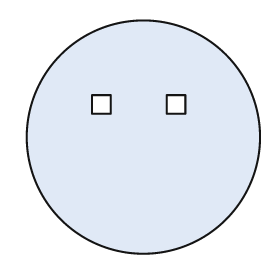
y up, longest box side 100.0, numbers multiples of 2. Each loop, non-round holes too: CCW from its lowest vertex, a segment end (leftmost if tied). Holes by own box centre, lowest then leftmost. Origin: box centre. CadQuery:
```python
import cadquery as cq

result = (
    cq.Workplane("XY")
    .moveTo(0.0, 0.0)
    .circle(50.0)
    .moveTo(-22.0, 10.0)
    .lineTo(-14.0, 10.0)
    .lineTo(-14.0, 18.0)
    .lineTo(-22.0, 18.0)
    .close()
    .moveTo(10.0, 10.0)
    .lineTo(18.0, 10.0)
    .lineTo(18.0, 18.0)
    .lineTo(10.0, 18.0)
    .close()
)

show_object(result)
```